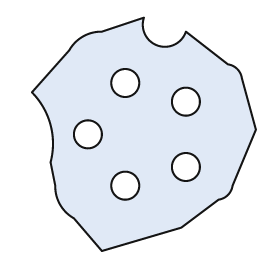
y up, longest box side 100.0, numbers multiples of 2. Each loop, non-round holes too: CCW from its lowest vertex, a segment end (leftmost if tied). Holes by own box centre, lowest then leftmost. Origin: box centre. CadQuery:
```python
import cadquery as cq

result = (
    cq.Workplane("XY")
    .moveTo(-18.0, -50.0)
    .lineTo(16.0, -40.0)
    .lineTo(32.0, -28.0)
    .threePointArc((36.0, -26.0), (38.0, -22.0))
    .lineTo(48.0, 2.0)
    .lineTo(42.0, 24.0)
    .threePointArc((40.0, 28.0), (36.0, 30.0))
    .lineTo(18.0, 44.0)
    .threePointArc((6.0, 38.0), (0.0, 50.0))
    .lineTo(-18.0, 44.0)
    .threePointArc((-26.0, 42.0), (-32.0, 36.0))
    .lineTo(-48.0, 18.0)
    .threePointArc((-40.0, 4.0), (-40.0, -12.0))
    .lineTo(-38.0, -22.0)
    .threePointArc((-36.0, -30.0), (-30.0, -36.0))
    .close()
    .moveTo(-8.0, -22.0)
    .circle(6.0)
    .moveTo(18.0, -14.0)
    .circle(6.0)
    .moveTo(-24.0, 0.0)
    .circle(6.0)
    .moveTo(18.0, 14.0)
    .circle(6.0)
    .moveTo(-8.0, 22.0)
    .circle(6.0)
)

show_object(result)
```